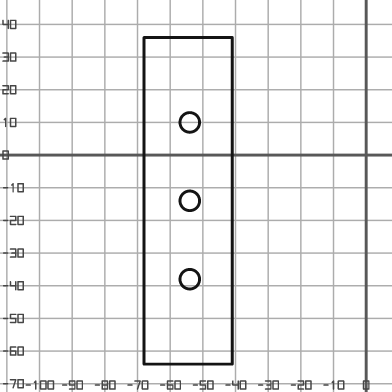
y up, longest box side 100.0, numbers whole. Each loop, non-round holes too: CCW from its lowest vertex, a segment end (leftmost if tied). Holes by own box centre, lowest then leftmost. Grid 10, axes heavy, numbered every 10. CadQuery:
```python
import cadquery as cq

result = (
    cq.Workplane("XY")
    .moveTo(-68.0, -64.0)
    .lineTo(-41.0, -64.0)
    .lineTo(-41.0, 36.0)
    .lineTo(-68.0, 36.0)
    .close()
    .moveTo(-54.0, -38.0)
    .circle(3.0)
    .moveTo(-54.0, -14.0)
    .circle(3.0)
    .moveTo(-54.0, 10.0)
    .circle(3.0)
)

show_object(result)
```